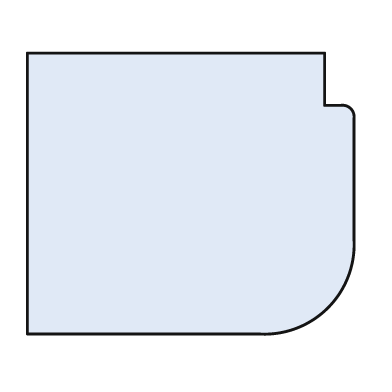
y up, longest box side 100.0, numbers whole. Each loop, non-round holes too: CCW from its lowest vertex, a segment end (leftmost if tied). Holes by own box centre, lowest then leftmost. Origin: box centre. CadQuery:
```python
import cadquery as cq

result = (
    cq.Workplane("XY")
    .moveTo(-50.0, -43.0)
    .lineTo(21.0, -43.0)
    .threePointArc((42.0, -35.0), (50.0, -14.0))
    .lineTo(50.0, 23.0)
    .threePointArc((49.0, 26.0), (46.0, 27.0))
    .lineTo(41.0, 27.0)
    .lineTo(41.0, 43.0)
    .lineTo(-50.0, 43.0)
    .close()
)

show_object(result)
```